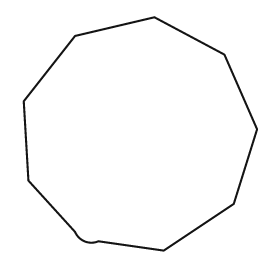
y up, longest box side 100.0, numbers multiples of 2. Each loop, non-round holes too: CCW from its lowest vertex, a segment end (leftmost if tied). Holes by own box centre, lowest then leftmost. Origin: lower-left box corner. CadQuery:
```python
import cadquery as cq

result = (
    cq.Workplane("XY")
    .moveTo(60.0, 0.0)
    .lineTo(90.0, 20.0)
    .lineTo(100.0, 52.0)
    .lineTo(86.0, 84.0)
    .lineTo(56.0, 100.0)
    .lineTo(22.0, 92.0)
    .lineTo(0.0, 64.0)
    .lineTo(2.0, 30.0)
    .lineTo(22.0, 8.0)
    .threePointArc((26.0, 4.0), (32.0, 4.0))
    .close()
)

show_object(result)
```